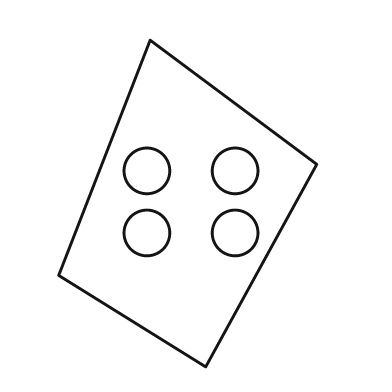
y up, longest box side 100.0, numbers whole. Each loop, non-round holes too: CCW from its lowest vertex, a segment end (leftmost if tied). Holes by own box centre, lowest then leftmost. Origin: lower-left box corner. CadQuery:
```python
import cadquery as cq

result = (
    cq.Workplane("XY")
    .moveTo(45.0, 0.0)
    .lineTo(79.0, 62.0)
    .lineTo(28.0, 100.0)
    .lineTo(0.0, 28.0)
    .close()
    .moveTo(27.0, 41.0)
    .circle(7.0)
    .moveTo(54.0, 41.0)
    .circle(7.0)
    .moveTo(27.0, 60.0)
    .circle(7.0)
    .moveTo(54.0, 60.0)
    .circle(7.0)
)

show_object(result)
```